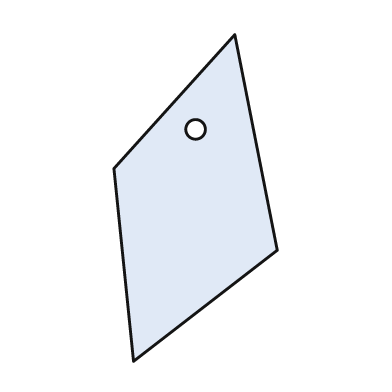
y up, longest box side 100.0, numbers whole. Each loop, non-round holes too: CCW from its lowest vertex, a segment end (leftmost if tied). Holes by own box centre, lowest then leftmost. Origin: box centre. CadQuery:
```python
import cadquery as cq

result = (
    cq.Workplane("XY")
    .moveTo(-19.0, -50.0)
    .lineTo(25.0, -16.0)
    .lineTo(12.0, 50.0)
    .lineTo(-25.0, 9.0)
    .close()
    .moveTo(0.0, 21.0)
    .circle(3.0)
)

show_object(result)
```